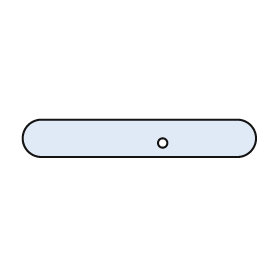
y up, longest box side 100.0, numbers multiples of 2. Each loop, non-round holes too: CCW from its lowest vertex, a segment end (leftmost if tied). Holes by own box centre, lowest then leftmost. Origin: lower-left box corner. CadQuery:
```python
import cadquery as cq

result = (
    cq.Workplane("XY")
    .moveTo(8.0, 0.0)
    .lineTo(92.0, 0.0)
    .threePointArc((100.0, 8.0), (92.0, 16.0))
    .lineTo(8.0, 16.0)
    .threePointArc((0.0, 8.0), (8.0, 0.0))
    .close()
    .moveTo(60.0, 6.0)
    .circle(2.0)
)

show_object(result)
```